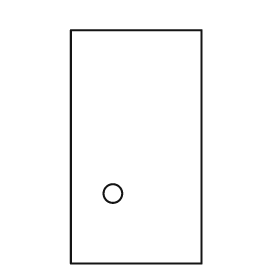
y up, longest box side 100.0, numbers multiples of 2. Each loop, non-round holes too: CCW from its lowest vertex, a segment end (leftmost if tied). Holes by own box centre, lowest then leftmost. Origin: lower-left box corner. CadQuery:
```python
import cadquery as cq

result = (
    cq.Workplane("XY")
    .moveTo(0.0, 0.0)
    .lineTo(56.0, 0.0)
    .lineTo(56.0, 100.0)
    .lineTo(0.0, 100.0)
    .close()
    .moveTo(18.0, 30.0)
    .circle(4.0)
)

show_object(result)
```